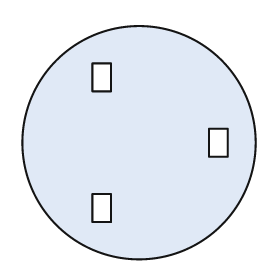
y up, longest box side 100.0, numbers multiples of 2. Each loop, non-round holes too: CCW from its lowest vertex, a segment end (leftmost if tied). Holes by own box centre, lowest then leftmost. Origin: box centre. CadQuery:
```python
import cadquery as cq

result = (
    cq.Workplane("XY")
    .moveTo(0.0, 0.0)
    .circle(50.0)
    .moveTo(-20.0, -34.0)
    .lineTo(-12.0, -34.0)
    .lineTo(-12.0, -22.0)
    .lineTo(-20.0, -22.0)
    .close()
    .moveTo(30.0, -6.0)
    .lineTo(38.0, -6.0)
    .lineTo(38.0, 6.0)
    .lineTo(30.0, 6.0)
    .close()
    .moveTo(-20.0, 22.0)
    .lineTo(-12.0, 22.0)
    .lineTo(-12.0, 34.0)
    .lineTo(-20.0, 34.0)
    .close()
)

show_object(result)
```